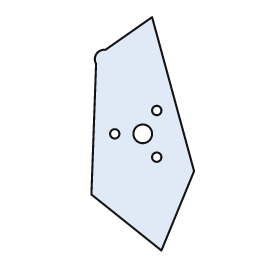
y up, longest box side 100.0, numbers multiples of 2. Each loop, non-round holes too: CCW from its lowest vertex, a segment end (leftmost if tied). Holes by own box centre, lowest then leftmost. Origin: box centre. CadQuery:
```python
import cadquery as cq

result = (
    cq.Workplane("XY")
    .moveTo(8.0, -50.0)
    .lineTo(22.0, -16.0)
    .lineTo(4.0, 50.0)
    .lineTo(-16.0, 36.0)
    .threePointArc((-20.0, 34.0), (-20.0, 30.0))
    .lineTo(-22.0, -26.0)
    .close()
    .moveTo(6.0, -10.0)
    .circle(2.0)
    .moveTo(-12.0, 0.0)
    .circle(2.0)
    .moveTo(0.0, 0.0)
    .circle(4.0)
    .moveTo(6.0, 10.0)
    .circle(2.0)
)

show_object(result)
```